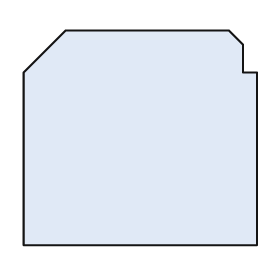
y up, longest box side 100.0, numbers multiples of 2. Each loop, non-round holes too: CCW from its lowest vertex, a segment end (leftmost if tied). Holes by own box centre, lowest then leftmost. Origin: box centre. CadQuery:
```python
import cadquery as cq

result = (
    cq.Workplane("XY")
    .moveTo(-50.0, -46.0)
    .lineTo(50.0, -46.0)
    .lineTo(50.0, 28.0)
    .lineTo(44.0, 28.0)
    .lineTo(44.0, 40.0)
    .lineTo(38.0, 46.0)
    .lineTo(-32.0, 46.0)
    .lineTo(-50.0, 28.0)
    .close()
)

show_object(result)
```